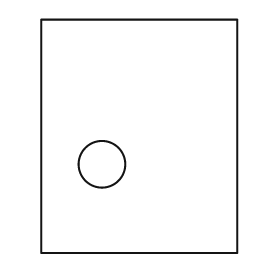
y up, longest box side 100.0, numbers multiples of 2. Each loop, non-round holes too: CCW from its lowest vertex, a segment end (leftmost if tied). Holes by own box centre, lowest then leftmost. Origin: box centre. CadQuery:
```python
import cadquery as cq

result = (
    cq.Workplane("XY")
    .moveTo(-42.0, -50.0)
    .lineTo(42.0, -50.0)
    .lineTo(42.0, 50.0)
    .lineTo(-42.0, 50.0)
    .close()
    .moveTo(-16.0, -12.0)
    .circle(10.0)
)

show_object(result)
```